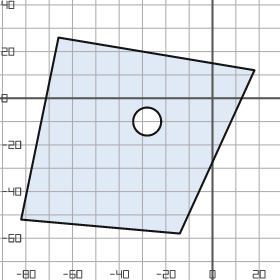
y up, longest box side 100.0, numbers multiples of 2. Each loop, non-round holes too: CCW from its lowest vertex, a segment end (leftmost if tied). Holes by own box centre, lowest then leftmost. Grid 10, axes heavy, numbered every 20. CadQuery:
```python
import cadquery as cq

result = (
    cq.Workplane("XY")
    .moveTo(-14.0, -58.0)
    .lineTo(18.0, 12.0)
    .lineTo(-66.0, 26.0)
    .lineTo(-82.0, -52.0)
    .close()
    .moveTo(-28.0, -10.0)
    .circle(6.0)
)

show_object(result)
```